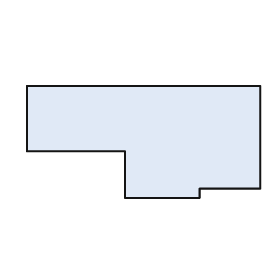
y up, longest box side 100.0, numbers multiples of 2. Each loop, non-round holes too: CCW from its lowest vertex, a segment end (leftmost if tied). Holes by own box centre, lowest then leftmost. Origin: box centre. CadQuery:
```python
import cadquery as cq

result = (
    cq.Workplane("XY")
    .moveTo(-8.0, -24.0)
    .lineTo(24.0, -24.0)
    .lineTo(24.0, -20.0)
    .lineTo(50.0, -20.0)
    .lineTo(50.0, 24.0)
    .lineTo(-50.0, 24.0)
    .lineTo(-50.0, -4.0)
    .lineTo(-8.0, -4.0)
    .close()
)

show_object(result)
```